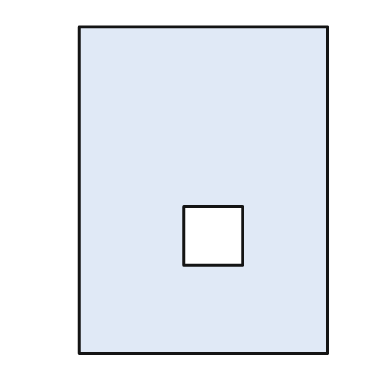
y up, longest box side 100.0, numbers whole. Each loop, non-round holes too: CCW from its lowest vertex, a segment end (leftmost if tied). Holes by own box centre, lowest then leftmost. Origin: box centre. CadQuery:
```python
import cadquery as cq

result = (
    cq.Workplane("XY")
    .moveTo(-38.0, -50.0)
    .lineTo(38.0, -50.0)
    .lineTo(38.0, 50.0)
    .lineTo(-38.0, 50.0)
    .close()
    .moveTo(-6.0, -23.0)
    .lineTo(12.0, -23.0)
    .lineTo(12.0, -5.0)
    .lineTo(-6.0, -5.0)
    .close()
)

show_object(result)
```